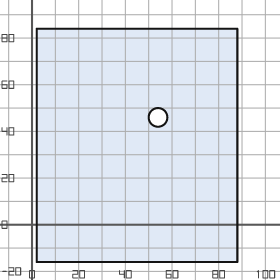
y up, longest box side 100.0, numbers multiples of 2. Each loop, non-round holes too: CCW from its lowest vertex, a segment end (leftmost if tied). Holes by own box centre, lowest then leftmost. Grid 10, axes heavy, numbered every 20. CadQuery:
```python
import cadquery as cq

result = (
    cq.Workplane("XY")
    .moveTo(2.0, -16.0)
    .lineTo(88.0, -16.0)
    .lineTo(88.0, 84.0)
    .lineTo(2.0, 84.0)
    .close()
    .moveTo(54.0, 46.0)
    .circle(4.0)
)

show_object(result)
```